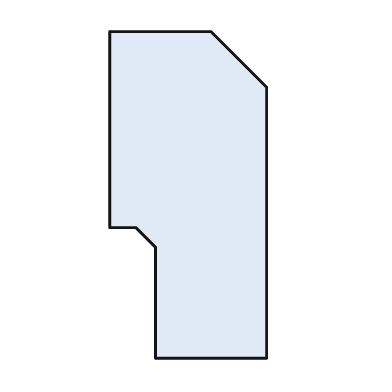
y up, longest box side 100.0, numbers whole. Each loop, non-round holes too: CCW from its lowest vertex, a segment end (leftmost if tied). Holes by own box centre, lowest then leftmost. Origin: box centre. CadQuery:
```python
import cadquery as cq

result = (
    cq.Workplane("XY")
    .moveTo(-10.0, -50.0)
    .lineTo(24.0, -50.0)
    .lineTo(24.0, 33.0)
    .lineTo(7.0, 50.0)
    .lineTo(-24.0, 50.0)
    .lineTo(-24.0, -10.0)
    .lineTo(-16.0, -10.0)
    .lineTo(-10.0, -16.0)
    .close()
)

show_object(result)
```